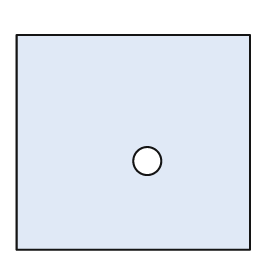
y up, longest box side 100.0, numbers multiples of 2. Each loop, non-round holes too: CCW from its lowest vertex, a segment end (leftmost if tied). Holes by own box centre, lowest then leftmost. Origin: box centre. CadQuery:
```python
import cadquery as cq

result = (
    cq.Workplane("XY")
    .moveTo(-50.0, -46.0)
    .lineTo(50.0, -46.0)
    .lineTo(50.0, 46.0)
    .lineTo(-50.0, 46.0)
    .close()
    .moveTo(6.0, -8.0)
    .circle(6.0)
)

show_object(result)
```